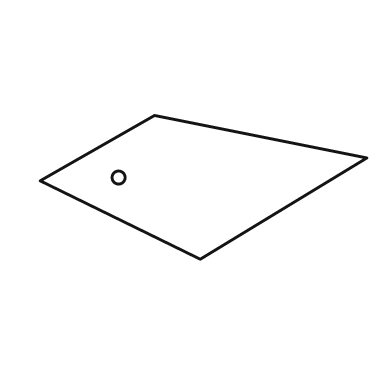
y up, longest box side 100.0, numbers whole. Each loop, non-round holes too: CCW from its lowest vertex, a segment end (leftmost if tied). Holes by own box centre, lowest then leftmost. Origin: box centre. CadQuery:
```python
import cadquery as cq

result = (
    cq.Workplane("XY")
    .moveTo(-1.0, -22.0)
    .lineTo(50.0, 9.0)
    .lineTo(-15.0, 22.0)
    .lineTo(-50.0, 2.0)
    .close()
    .moveTo(-26.0, 3.0)
    .circle(2.0)
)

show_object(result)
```